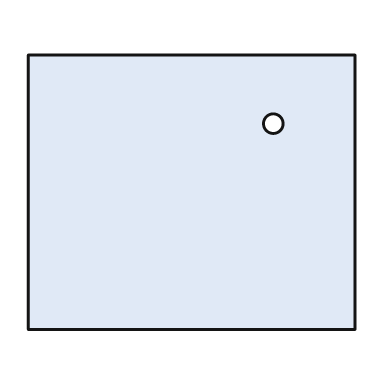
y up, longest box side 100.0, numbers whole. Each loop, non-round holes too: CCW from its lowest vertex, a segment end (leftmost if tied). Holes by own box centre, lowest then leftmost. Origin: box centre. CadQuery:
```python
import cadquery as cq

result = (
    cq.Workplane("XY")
    .moveTo(-50.0, -42.0)
    .lineTo(50.0, -42.0)
    .lineTo(50.0, 42.0)
    .lineTo(-50.0, 42.0)
    .close()
    .moveTo(25.0, 21.0)
    .circle(3.0)
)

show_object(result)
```